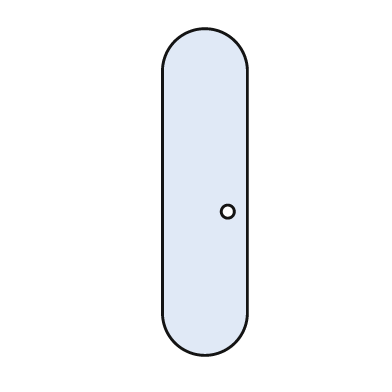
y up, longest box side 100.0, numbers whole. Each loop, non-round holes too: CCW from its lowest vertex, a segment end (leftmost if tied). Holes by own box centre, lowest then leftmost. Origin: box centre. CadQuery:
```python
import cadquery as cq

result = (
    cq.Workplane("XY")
    .moveTo(-13.0, -37.0)
    .threePointArc((0.0, -50.0), (13.0, -37.0))
    .lineTo(13.0, 37.0)
    .threePointArc((0.0, 50.0), (-13.0, 37.0))
    .close()
    .moveTo(7.0, -6.0)
    .circle(2.0)
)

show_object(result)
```